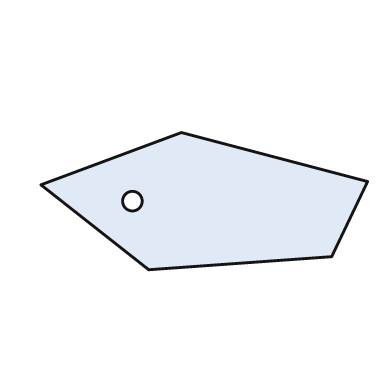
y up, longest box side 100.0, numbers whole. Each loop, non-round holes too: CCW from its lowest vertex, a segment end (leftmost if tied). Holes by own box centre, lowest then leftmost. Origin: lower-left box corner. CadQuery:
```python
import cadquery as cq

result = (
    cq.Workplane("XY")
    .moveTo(33.0, 0.0)
    .lineTo(89.0, 4.0)
    .lineTo(100.0, 27.0)
    .lineTo(43.0, 42.0)
    .lineTo(0.0, 26.0)
    .close()
    .moveTo(28.0, 21.0)
    .circle(3.0)
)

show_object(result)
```